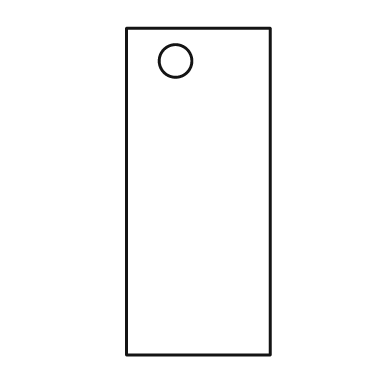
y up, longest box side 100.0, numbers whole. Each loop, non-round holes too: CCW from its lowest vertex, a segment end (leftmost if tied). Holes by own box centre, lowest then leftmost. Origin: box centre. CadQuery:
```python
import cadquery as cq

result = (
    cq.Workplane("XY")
    .moveTo(-22.0, -50.0)
    .lineTo(22.0, -50.0)
    .lineTo(22.0, 50.0)
    .lineTo(-22.0, 50.0)
    .close()
    .moveTo(-7.0, 40.0)
    .circle(5.0)
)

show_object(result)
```